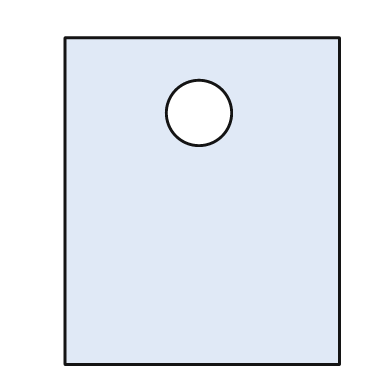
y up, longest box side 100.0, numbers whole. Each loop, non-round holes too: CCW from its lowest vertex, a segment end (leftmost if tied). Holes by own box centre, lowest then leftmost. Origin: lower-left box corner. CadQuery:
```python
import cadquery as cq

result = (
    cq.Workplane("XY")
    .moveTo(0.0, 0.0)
    .lineTo(84.0, 0.0)
    .lineTo(84.0, 100.0)
    .lineTo(0.0, 100.0)
    .close()
    .moveTo(41.0, 77.0)
    .circle(10.0)
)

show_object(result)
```